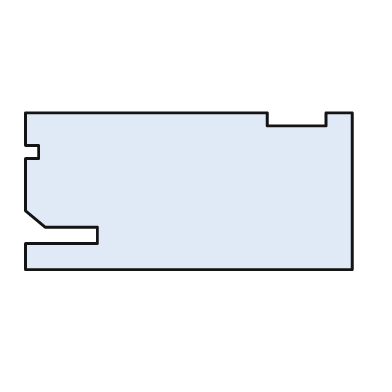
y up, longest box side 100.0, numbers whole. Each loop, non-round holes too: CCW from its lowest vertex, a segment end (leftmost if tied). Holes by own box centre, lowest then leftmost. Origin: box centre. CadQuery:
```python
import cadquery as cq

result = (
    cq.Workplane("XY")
    .moveTo(-50.0, -24.0)
    .lineTo(50.0, -24.0)
    .lineTo(50.0, 24.0)
    .lineTo(42.0, 24.0)
    .lineTo(42.0, 20.0)
    .lineTo(24.0, 20.0)
    .lineTo(24.0, 24.0)
    .lineTo(-50.0, 24.0)
    .lineTo(-50.0, 14.0)
    .lineTo(-46.0, 14.0)
    .lineTo(-46.0, 10.0)
    .lineTo(-50.0, 10.0)
    .lineTo(-50.0, -6.0)
    .lineTo(-44.0, -11.0)
    .lineTo(-28.0, -11.0)
    .lineTo(-28.0, -16.0)
    .lineTo(-50.0, -16.0)
    .close()
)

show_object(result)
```